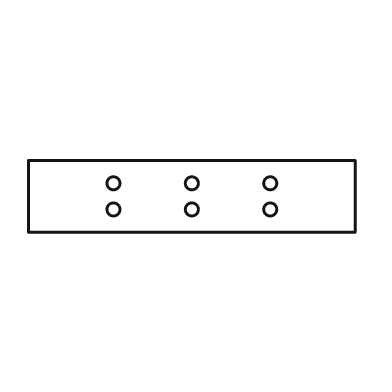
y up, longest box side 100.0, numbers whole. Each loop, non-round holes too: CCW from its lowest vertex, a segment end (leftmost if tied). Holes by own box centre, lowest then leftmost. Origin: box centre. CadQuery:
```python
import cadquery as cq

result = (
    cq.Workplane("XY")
    .moveTo(-50.0, -11.0)
    .lineTo(50.0, -11.0)
    .lineTo(50.0, 11.0)
    .lineTo(-50.0, 11.0)
    .close()
    .moveTo(-24.0, -4.0)
    .circle(2.0)
    .moveTo(0.0, -4.0)
    .circle(2.0)
    .moveTo(24.0, -4.0)
    .circle(2.0)
    .moveTo(-24.0, 4.0)
    .circle(2.0)
    .moveTo(0.0, 4.0)
    .circle(2.0)
    .moveTo(24.0, 4.0)
    .circle(2.0)
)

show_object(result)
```